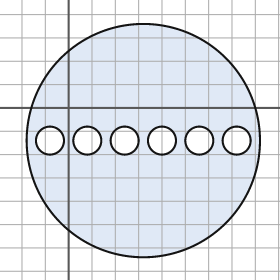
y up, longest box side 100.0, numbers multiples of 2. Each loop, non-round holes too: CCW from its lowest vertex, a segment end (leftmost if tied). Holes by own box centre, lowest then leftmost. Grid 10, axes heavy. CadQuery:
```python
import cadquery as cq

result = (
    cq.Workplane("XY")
    .moveTo(32.0, -14.0)
    .circle(50.0)
    .moveTo(-8.0, -14.0)
    .circle(6.0)
    .moveTo(8.0, -14.0)
    .circle(6.0)
    .moveTo(24.0, -14.0)
    .circle(6.0)
    .moveTo(40.0, -14.0)
    .circle(6.0)
    .moveTo(56.0, -14.0)
    .circle(6.0)
    .moveTo(72.0, -14.0)
    .circle(6.0)
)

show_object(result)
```